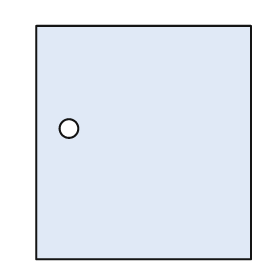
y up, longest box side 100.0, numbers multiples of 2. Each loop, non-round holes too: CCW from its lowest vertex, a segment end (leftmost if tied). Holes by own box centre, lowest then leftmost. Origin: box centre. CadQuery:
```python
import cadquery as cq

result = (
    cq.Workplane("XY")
    .moveTo(-46.0, -50.0)
    .lineTo(46.0, -50.0)
    .lineTo(46.0, 50.0)
    .lineTo(-46.0, 50.0)
    .close()
    .moveTo(-32.0, 6.0)
    .circle(4.0)
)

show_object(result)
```